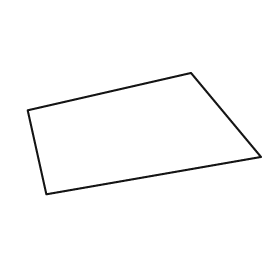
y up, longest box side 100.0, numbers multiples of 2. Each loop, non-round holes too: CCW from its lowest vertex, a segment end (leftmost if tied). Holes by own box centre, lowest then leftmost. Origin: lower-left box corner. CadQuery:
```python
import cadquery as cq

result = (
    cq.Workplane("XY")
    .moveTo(8.0, 0.0)
    .lineTo(100.0, 16.0)
    .lineTo(70.0, 52.0)
    .lineTo(0.0, 36.0)
    .close()
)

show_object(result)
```